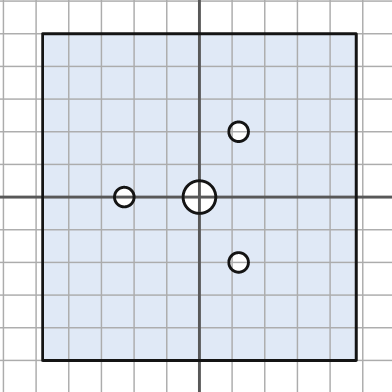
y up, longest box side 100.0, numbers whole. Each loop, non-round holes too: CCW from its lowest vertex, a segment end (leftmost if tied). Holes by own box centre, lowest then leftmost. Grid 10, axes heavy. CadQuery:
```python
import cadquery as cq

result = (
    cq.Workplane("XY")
    .moveTo(-48.0, -50.0)
    .lineTo(48.0, -50.0)
    .lineTo(48.0, 50.0)
    .lineTo(-48.0, 50.0)
    .close()
    .moveTo(12.0, -20.0)
    .circle(3.0)
    .moveTo(-23.0, 0.0)
    .circle(3.0)
    .moveTo(0.0, 0.0)
    .circle(5.0)
    .moveTo(12.0, 20.0)
    .circle(3.0)
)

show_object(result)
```